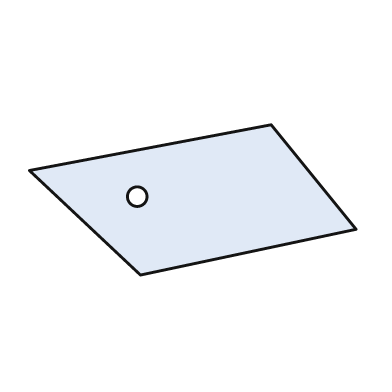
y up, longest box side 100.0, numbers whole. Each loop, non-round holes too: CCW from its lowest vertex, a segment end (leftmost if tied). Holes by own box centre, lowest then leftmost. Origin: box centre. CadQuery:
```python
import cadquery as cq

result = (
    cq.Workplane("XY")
    .moveTo(-16.0, -23.0)
    .lineTo(50.0, -9.0)
    .lineTo(24.0, 23.0)
    .lineTo(-50.0, 9.0)
    .close()
    .moveTo(-17.0, 1.0)
    .circle(3.0)
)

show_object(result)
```